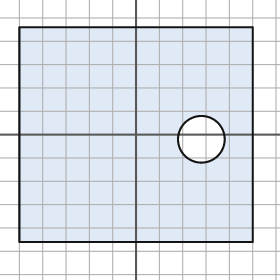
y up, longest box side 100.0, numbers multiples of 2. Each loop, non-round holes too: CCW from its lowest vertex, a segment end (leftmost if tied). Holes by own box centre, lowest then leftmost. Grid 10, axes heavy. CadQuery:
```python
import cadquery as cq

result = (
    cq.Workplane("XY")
    .moveTo(-50.0, -46.0)
    .lineTo(50.0, -46.0)
    .lineTo(50.0, 46.0)
    .lineTo(-50.0, 46.0)
    .close()
    .moveTo(28.0, -2.0)
    .circle(10.0)
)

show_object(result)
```